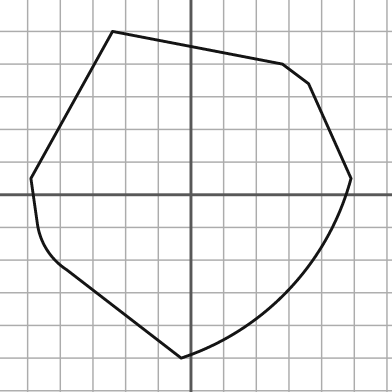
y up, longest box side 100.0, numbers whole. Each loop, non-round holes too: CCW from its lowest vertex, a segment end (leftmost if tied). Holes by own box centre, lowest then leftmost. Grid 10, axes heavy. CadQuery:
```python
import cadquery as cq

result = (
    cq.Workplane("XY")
    .moveTo(-3.0, -50.0)
    .threePointArc((30.0, -29.0), (49.0, 5.0))
    .lineTo(36.0, 34.0)
    .lineTo(28.0, 40.0)
    .lineTo(-24.0, 50.0)
    .lineTo(-49.0, 5.0)
    .lineTo(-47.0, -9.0)
    .threePointArc((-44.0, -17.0), (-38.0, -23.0))
    .close()
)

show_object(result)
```